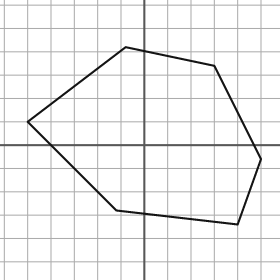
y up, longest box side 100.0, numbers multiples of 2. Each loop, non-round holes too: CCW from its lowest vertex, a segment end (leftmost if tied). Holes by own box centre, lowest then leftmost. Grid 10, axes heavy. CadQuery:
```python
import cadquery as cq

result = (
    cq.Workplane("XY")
    .moveTo(40.0, -34.0)
    .lineTo(50.0, -6.0)
    .lineTo(30.0, 34.0)
    .lineTo(-8.0, 42.0)
    .lineTo(-50.0, 10.0)
    .lineTo(-12.0, -28.0)
    .close()
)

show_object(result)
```